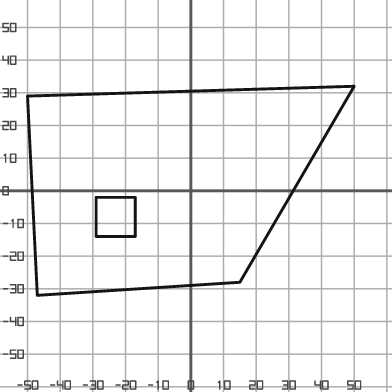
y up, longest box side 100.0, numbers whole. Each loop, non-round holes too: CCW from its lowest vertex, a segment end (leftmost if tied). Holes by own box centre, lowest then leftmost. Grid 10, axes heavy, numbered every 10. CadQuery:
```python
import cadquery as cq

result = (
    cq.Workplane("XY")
    .moveTo(-47.0, -32.0)
    .lineTo(15.0, -28.0)
    .lineTo(50.0, 32.0)
    .lineTo(-50.0, 29.0)
    .close()
    .moveTo(-29.0, -14.0)
    .lineTo(-17.0, -14.0)
    .lineTo(-17.0, -2.0)
    .lineTo(-29.0, -2.0)
    .close()
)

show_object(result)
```